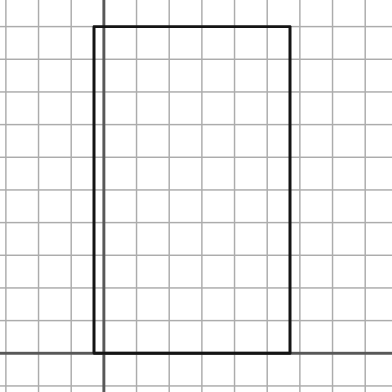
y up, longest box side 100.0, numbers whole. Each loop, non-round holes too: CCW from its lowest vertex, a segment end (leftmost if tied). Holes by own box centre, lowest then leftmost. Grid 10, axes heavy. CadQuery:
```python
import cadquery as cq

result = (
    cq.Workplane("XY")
    .moveTo(-3.0, 0.0)
    .lineTo(57.0, 0.0)
    .lineTo(57.0, 100.0)
    .lineTo(-3.0, 100.0)
    .close()
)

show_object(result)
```